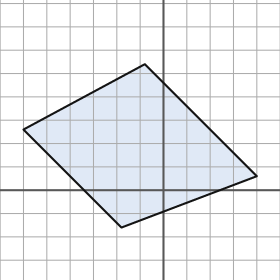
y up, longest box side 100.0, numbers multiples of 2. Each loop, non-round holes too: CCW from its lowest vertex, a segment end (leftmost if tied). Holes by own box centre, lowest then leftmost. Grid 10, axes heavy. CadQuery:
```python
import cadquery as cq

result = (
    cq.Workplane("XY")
    .moveTo(-18.0, -16.0)
    .lineTo(40.0, 6.0)
    .lineTo(-8.0, 54.0)
    .lineTo(-60.0, 26.0)
    .close()
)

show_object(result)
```